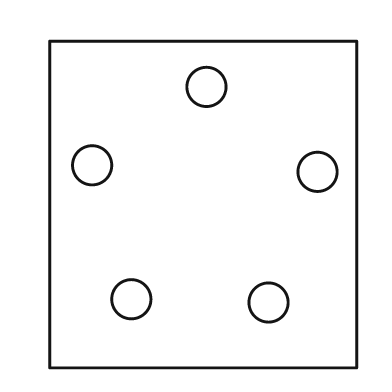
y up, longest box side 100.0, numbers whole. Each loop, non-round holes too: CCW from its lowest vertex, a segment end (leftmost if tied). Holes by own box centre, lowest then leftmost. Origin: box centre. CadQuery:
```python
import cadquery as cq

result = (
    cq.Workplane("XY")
    .moveTo(-47.0, -50.0)
    .lineTo(47.0, -50.0)
    .lineTo(47.0, 50.0)
    .lineTo(-47.0, 50.0)
    .close()
    .moveTo(20.0, -30.0)
    .circle(6.0)
    .moveTo(-22.0, -29.0)
    .circle(6.0)
    .moveTo(35.0, 10.0)
    .circle(6.0)
    .moveTo(-34.0, 12.0)
    .circle(6.0)
    .moveTo(1.0, 36.0)
    .circle(6.0)
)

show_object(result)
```